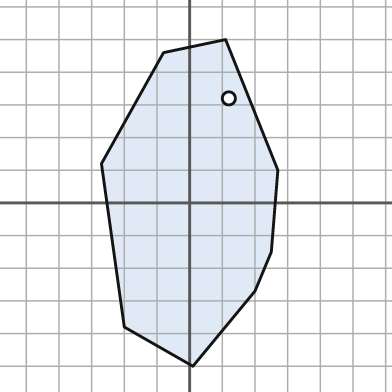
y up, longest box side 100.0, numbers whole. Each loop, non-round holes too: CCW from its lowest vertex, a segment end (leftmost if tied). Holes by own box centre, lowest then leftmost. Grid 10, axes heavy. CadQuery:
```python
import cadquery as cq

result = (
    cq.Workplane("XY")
    .moveTo(1.0, -50.0)
    .lineTo(20.0, -27.0)
    .lineTo(25.0, -15.0)
    .lineTo(27.0, 10.0)
    .lineTo(11.0, 50.0)
    .lineTo(-8.0, 46.0)
    .lineTo(-27.0, 12.0)
    .lineTo(-20.0, -38.0)
    .close()
    .moveTo(12.0, 32.0)
    .circle(2.0)
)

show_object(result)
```